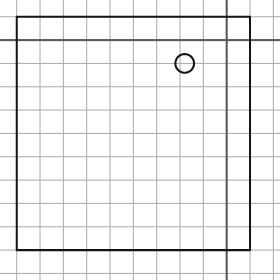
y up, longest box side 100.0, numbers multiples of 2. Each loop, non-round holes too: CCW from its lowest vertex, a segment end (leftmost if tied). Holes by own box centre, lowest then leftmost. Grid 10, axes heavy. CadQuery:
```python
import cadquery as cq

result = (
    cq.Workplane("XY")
    .moveTo(-90.0, -90.0)
    .lineTo(10.0, -90.0)
    .lineTo(10.0, 10.0)
    .lineTo(-90.0, 10.0)
    .close()
    .moveTo(-18.0, -10.0)
    .circle(4.0)
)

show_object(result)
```